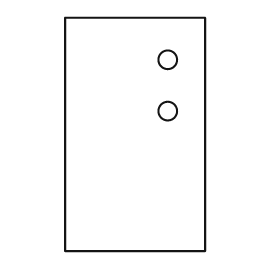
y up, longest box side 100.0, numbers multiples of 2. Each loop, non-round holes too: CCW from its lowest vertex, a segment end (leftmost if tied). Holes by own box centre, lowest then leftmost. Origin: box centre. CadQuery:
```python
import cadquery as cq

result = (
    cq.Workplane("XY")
    .moveTo(-30.0, -50.0)
    .lineTo(30.0, -50.0)
    .lineTo(30.0, 50.0)
    .lineTo(-30.0, 50.0)
    .close()
    .moveTo(14.0, 10.0)
    .circle(4.0)
    .moveTo(14.0, 32.0)
    .circle(4.0)
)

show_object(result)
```